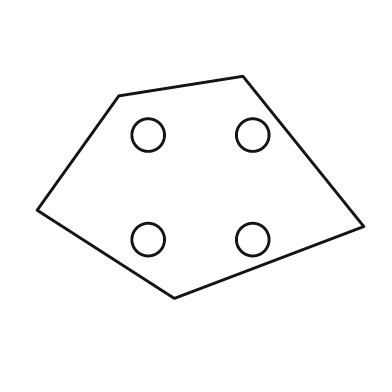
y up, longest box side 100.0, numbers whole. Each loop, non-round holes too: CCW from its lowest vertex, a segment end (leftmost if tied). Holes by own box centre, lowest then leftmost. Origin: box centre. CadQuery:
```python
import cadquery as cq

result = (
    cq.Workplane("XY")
    .moveTo(-8.0, -34.0)
    .lineTo(50.0, -12.0)
    .lineTo(13.0, 34.0)
    .lineTo(-25.0, 28.0)
    .lineTo(-50.0, -7.0)
    .close()
    .moveTo(-16.0, -16.0)
    .circle(5.0)
    .moveTo(16.0, -16.0)
    .circle(5.0)
    .moveTo(-16.0, 16.0)
    .circle(5.0)
    .moveTo(16.0, 16.0)
    .circle(5.0)
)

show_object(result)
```